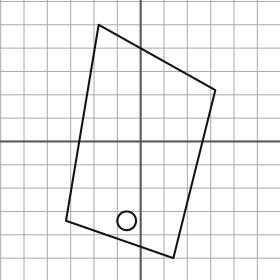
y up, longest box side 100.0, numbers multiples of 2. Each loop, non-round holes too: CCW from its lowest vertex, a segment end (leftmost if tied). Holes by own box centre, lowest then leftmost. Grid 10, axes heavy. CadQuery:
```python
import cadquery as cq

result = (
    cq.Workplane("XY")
    .moveTo(14.0, -50.0)
    .lineTo(32.0, 22.0)
    .lineTo(-18.0, 50.0)
    .lineTo(-32.0, -34.0)
    .close()
    .moveTo(-6.0, -34.0)
    .circle(4.0)
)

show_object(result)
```